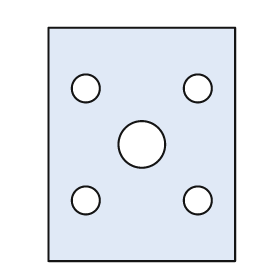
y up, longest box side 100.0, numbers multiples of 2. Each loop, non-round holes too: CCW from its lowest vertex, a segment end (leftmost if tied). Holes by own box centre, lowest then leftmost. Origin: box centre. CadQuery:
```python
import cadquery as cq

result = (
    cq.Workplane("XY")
    .moveTo(-40.0, -50.0)
    .lineTo(40.0, -50.0)
    .lineTo(40.0, 50.0)
    .lineTo(-40.0, 50.0)
    .close()
    .moveTo(-24.0, -24.0)
    .circle(6.0)
    .moveTo(24.0, -24.0)
    .circle(6.0)
    .moveTo(0.0, 0.0)
    .circle(10.0)
    .moveTo(-24.0, 24.0)
    .circle(6.0)
    .moveTo(24.0, 24.0)
    .circle(6.0)
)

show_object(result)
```